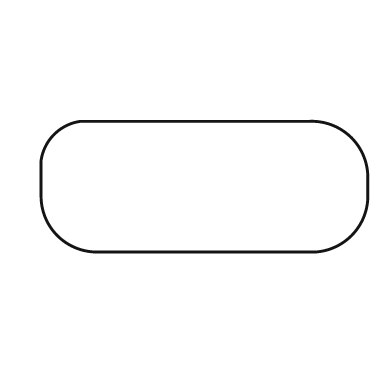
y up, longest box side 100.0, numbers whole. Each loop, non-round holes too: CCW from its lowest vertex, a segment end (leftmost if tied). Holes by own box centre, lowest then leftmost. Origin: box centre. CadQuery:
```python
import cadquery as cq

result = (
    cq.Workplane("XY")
    .moveTo(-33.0, -20.0)
    .lineTo(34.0, -20.0)
    .threePointArc((45.0, -15.0), (50.0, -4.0))
    .lineTo(50.0, 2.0)
    .threePointArc((45.0, 15.0), (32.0, 20.0))
    .lineTo(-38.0, 20.0)
    .threePointArc((-46.0, 16.0), (-50.0, 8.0))
    .lineTo(-50.0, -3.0)
    .threePointArc((-45.0, -15.0), (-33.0, -20.0))
    .close()
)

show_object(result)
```